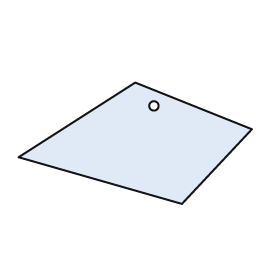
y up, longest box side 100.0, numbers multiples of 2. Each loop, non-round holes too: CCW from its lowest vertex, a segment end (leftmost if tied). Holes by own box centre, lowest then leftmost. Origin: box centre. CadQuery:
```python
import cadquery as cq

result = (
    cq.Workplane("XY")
    .moveTo(20.0, -26.0)
    .lineTo(50.0, 6.0)
    .lineTo(0.0, 26.0)
    .lineTo(-50.0, -6.0)
    .close()
    .moveTo(8.0, 16.0)
    .circle(2.0)
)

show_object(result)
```